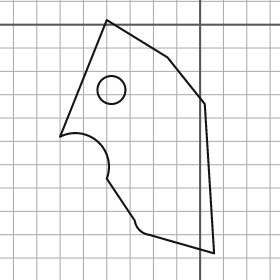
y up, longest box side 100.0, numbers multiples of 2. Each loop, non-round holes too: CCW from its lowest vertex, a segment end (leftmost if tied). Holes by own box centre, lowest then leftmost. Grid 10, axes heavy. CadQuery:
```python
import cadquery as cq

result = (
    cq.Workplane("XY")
    .moveTo(6.0, -98.0)
    .lineTo(2.0, -34.0)
    .lineTo(-14.0, -14.0)
    .lineTo(-40.0, 2.0)
    .lineTo(-60.0, -48.0)
    .threePointArc((-44.0, -50.0), (-40.0, -66.0))
    .lineTo(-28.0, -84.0)
    .threePointArc((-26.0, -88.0), (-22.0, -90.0))
    .close()
    .moveTo(-38.0, -28.0)
    .circle(6.0)
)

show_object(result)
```